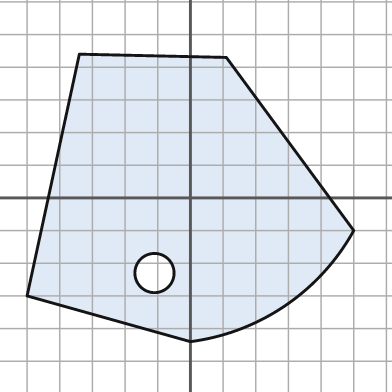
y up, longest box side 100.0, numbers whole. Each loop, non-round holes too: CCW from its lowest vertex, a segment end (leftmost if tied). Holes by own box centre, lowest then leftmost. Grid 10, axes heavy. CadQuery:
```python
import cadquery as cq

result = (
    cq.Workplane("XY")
    .moveTo(0.0, -44.0)
    .threePointArc((29.0, -33.0), (50.0, -10.0))
    .lineTo(11.0, 43.0)
    .lineTo(-34.0, 44.0)
    .lineTo(-50.0, -30.0)
    .close()
    .moveTo(-11.0, -23.0)
    .circle(6.0)
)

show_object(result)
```